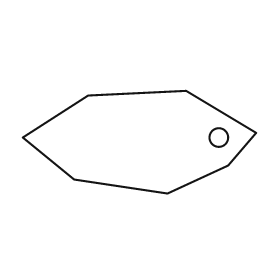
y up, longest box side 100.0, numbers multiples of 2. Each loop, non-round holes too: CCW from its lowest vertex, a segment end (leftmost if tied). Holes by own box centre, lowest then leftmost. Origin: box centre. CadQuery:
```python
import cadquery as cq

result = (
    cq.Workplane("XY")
    .moveTo(12.0, -22.0)
    .lineTo(38.0, -10.0)
    .lineTo(50.0, 4.0)
    .lineTo(20.0, 22.0)
    .lineTo(-22.0, 20.0)
    .lineTo(-50.0, 2.0)
    .lineTo(-28.0, -16.0)
    .close()
    .moveTo(34.0, 2.0)
    .circle(4.0)
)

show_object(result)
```